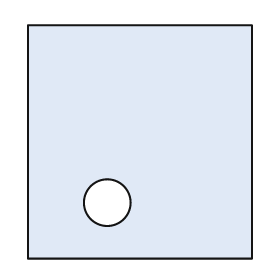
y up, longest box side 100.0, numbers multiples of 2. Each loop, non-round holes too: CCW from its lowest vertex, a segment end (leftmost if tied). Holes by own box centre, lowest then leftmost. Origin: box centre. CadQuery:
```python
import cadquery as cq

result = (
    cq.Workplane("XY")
    .moveTo(-48.0, -50.0)
    .lineTo(48.0, -50.0)
    .lineTo(48.0, 50.0)
    .lineTo(-48.0, 50.0)
    .close()
    .moveTo(-14.0, -26.0)
    .circle(10.0)
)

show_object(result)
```